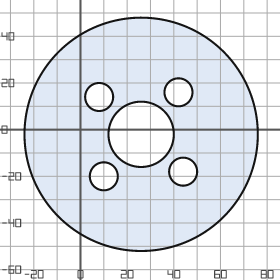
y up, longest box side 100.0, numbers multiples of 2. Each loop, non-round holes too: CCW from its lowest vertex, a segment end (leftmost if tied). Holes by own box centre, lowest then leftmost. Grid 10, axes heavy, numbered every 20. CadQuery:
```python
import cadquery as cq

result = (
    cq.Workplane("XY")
    .moveTo(26.0, -2.0)
    .circle(50.0)
    .moveTo(10.0, -20.0)
    .circle(6.0)
    .moveTo(44.0, -18.0)
    .circle(6.0)
    .moveTo(26.0, -2.0)
    .circle(14.0)
    .moveTo(8.0, 14.0)
    .circle(6.0)
    .moveTo(42.0, 16.0)
    .circle(6.0)
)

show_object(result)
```